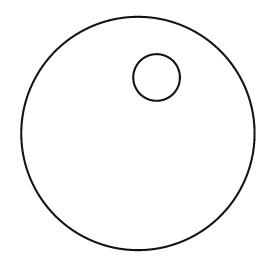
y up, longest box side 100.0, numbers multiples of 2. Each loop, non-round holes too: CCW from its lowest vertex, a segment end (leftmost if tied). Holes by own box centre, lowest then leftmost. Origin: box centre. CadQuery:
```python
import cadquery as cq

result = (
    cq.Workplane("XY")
    .moveTo(0.0, 0.0)
    .circle(50.0)
    .moveTo(8.0, 24.0)
    .circle(10.0)
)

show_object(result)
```